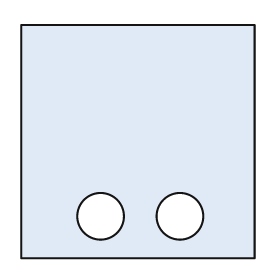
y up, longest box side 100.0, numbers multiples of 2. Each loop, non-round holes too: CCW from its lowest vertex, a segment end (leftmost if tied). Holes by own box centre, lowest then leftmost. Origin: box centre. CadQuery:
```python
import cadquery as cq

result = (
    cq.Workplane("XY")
    .moveTo(-50.0, -50.0)
    .lineTo(50.0, -50.0)
    .lineTo(50.0, 50.0)
    .lineTo(-50.0, 50.0)
    .close()
    .moveTo(-16.0, -32.0)
    .circle(10.0)
    .moveTo(18.0, -32.0)
    .circle(10.0)
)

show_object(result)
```